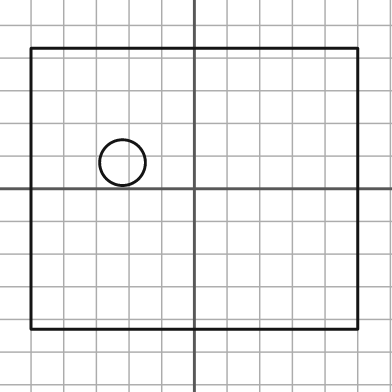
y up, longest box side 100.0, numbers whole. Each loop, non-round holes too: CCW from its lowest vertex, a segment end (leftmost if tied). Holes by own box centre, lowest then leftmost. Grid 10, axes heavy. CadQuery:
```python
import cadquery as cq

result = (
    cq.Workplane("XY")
    .moveTo(-50.0, -43.0)
    .lineTo(50.0, -43.0)
    .lineTo(50.0, 43.0)
    .lineTo(-50.0, 43.0)
    .close()
    .moveTo(-22.0, 8.0)
    .circle(7.0)
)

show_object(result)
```